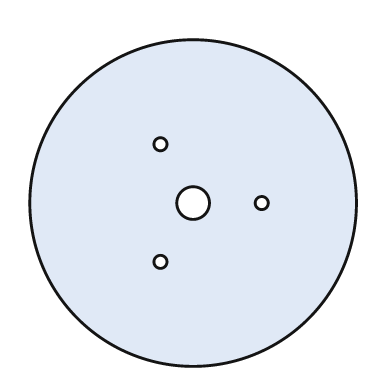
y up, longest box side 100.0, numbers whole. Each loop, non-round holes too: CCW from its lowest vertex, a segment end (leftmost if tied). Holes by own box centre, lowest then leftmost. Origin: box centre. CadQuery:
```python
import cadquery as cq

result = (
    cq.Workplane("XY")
    .moveTo(0.0, 0.0)
    .circle(50.0)
    .moveTo(-10.0, -18.0)
    .circle(2.0)
    .moveTo(0.0, 0.0)
    .circle(5.0)
    .moveTo(21.0, 0.0)
    .circle(2.0)
    .moveTo(-10.0, 18.0)
    .circle(2.0)
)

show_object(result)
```